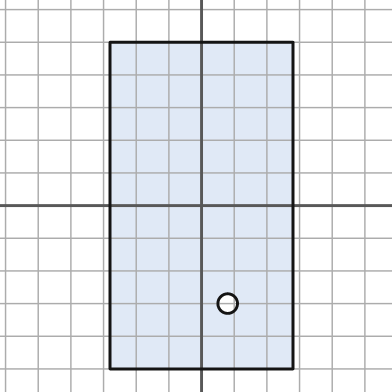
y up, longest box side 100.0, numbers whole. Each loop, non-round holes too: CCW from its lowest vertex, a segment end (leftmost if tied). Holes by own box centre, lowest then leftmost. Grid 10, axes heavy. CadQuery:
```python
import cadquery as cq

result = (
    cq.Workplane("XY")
    .moveTo(-28.0, -50.0)
    .lineTo(28.0, -50.0)
    .lineTo(28.0, 50.0)
    .lineTo(-28.0, 50.0)
    .close()
    .moveTo(8.0, -30.0)
    .circle(3.0)
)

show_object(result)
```